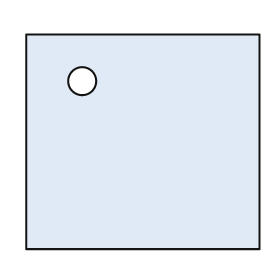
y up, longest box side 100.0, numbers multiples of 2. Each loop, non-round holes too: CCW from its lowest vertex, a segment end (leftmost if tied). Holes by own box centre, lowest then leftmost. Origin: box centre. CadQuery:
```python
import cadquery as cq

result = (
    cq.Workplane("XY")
    .moveTo(-50.0, -46.0)
    .lineTo(50.0, -46.0)
    .lineTo(50.0, 46.0)
    .lineTo(-50.0, 46.0)
    .close()
    .moveTo(-26.0, 26.0)
    .circle(6.0)
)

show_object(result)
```